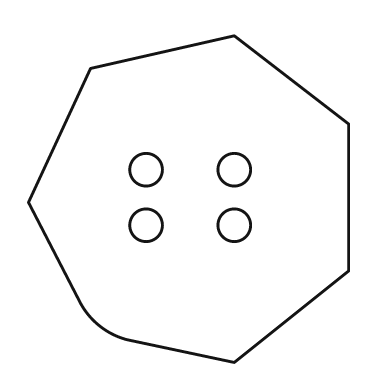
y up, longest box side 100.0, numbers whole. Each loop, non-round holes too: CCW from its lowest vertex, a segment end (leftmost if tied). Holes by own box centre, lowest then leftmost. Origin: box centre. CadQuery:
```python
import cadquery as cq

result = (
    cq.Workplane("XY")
    .moveTo(14.0, -50.0)
    .lineTo(49.0, -22.0)
    .lineTo(49.0, 23.0)
    .lineTo(14.0, 50.0)
    .lineTo(-30.0, 40.0)
    .lineTo(-49.0, -1.0)
    .lineTo(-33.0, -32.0)
    .threePointArc((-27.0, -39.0), (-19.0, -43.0))
    .close()
    .moveTo(-13.0, -8.0)
    .circle(5.0)
    .moveTo(14.0, -8.0)
    .circle(5.0)
    .moveTo(-13.0, 9.0)
    .circle(5.0)
    .moveTo(14.0, 9.0)
    .circle(5.0)
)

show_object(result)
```